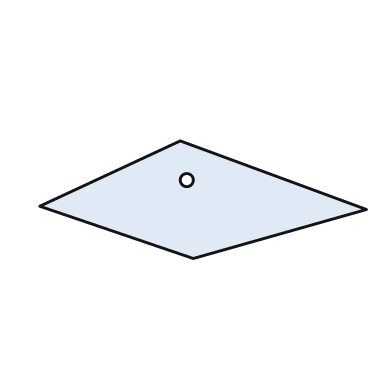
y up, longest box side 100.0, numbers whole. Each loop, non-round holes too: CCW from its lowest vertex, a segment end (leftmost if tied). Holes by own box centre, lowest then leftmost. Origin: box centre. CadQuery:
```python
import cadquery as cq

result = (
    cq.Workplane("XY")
    .moveTo(-3.0, -18.0)
    .lineTo(50.0, -3.0)
    .lineTo(-7.0, 18.0)
    .lineTo(-50.0, -2.0)
    .close()
    .moveTo(-5.0, 6.0)
    .circle(2.0)
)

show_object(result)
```